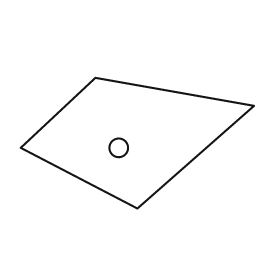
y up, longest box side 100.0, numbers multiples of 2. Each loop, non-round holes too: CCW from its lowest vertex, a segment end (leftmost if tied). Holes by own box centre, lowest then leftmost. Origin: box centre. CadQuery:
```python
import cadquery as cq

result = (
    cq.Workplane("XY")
    .moveTo(0.0, -28.0)
    .lineTo(50.0, 16.0)
    .lineTo(-18.0, 28.0)
    .lineTo(-50.0, -2.0)
    .close()
    .moveTo(-8.0, -2.0)
    .circle(4.0)
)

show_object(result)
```